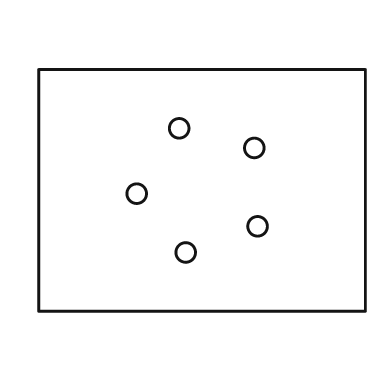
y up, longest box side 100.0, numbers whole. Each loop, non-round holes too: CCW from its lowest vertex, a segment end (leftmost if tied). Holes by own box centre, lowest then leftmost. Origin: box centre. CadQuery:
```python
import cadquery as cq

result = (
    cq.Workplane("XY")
    .moveTo(-50.0, -37.0)
    .lineTo(50.0, -37.0)
    .lineTo(50.0, 37.0)
    .lineTo(-50.0, 37.0)
    .close()
    .moveTo(-5.0, -19.0)
    .circle(3.0)
    .moveTo(17.0, -11.0)
    .circle(3.0)
    .moveTo(-20.0, -1.0)
    .circle(3.0)
    .moveTo(16.0, 13.0)
    .circle(3.0)
    .moveTo(-7.0, 19.0)
    .circle(3.0)
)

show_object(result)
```